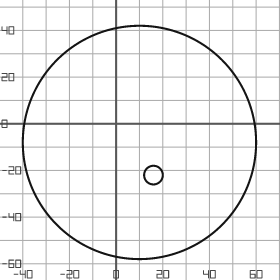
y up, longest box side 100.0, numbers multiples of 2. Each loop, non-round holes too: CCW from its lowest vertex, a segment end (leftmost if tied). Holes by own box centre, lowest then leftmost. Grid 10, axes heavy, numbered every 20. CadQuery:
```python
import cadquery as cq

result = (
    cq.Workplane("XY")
    .moveTo(10.0, -8.0)
    .circle(50.0)
    .moveTo(16.0, -22.0)
    .circle(4.0)
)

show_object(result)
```